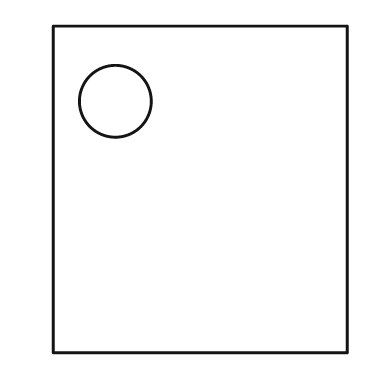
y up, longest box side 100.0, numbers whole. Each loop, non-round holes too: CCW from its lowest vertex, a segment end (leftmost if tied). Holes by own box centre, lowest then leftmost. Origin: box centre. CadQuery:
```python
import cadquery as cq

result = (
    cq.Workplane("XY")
    .moveTo(-45.0, -50.0)
    .lineTo(45.0, -50.0)
    .lineTo(45.0, 50.0)
    .lineTo(-45.0, 50.0)
    .close()
    .moveTo(-26.0, 27.0)
    .circle(11.0)
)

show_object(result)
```